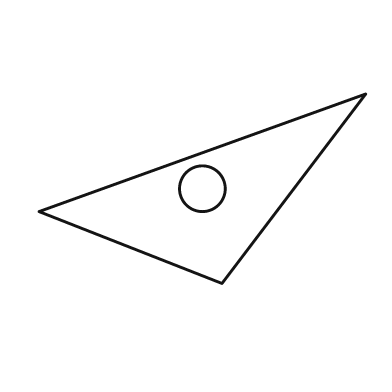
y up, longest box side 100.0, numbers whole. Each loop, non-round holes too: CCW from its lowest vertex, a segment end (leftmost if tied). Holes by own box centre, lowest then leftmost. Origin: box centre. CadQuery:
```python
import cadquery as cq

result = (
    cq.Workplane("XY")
    .moveTo(6.0, -29.0)
    .lineTo(50.0, 29.0)
    .lineTo(-50.0, -7.0)
    .close()
    .moveTo(0.0, 0.0)
    .circle(7.0)
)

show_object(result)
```